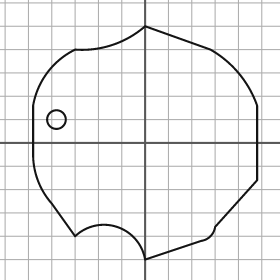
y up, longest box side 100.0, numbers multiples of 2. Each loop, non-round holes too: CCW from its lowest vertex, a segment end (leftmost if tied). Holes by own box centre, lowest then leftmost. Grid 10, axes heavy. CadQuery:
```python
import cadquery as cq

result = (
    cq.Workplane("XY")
    .moveTo(0.0, -50.0)
    .lineTo(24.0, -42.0)
    .threePointArc((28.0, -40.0), (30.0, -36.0))
    .lineTo(48.0, -16.0)
    .lineTo(48.0, 16.0)
    .threePointArc((40.0, 30.0), (28.0, 40.0))
    .lineTo(0.0, 50.0)
    .threePointArc((-14.0, 42.0), (-30.0, 40.0))
    .threePointArc((-42.0, 30.0), (-48.0, 16.0))
    .lineTo(-48.0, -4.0)
    .threePointArc((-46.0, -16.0), (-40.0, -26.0))
    .lineTo(-30.0, -40.0)
    .threePointArc((-12.0, -36.0), (0.0, -50.0))
    .close()
    .moveTo(-38.0, 10.0)
    .circle(4.0)
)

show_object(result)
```